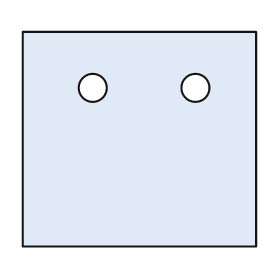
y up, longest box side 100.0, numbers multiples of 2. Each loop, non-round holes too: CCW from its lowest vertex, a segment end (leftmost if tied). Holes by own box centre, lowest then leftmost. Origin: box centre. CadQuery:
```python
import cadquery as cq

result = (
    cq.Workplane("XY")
    .moveTo(-50.0, -46.0)
    .lineTo(50.0, -46.0)
    .lineTo(50.0, 46.0)
    .lineTo(-50.0, 46.0)
    .close()
    .moveTo(-20.0, 22.0)
    .circle(6.0)
    .moveTo(24.0, 22.0)
    .circle(6.0)
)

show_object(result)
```